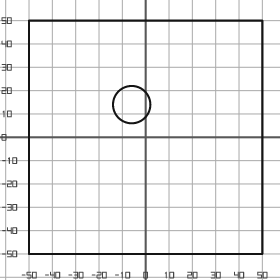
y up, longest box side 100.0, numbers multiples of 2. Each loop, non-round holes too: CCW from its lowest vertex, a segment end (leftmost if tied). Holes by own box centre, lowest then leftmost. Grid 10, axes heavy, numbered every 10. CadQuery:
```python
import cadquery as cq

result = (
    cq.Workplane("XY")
    .moveTo(-50.0, -50.0)
    .lineTo(50.0, -50.0)
    .lineTo(50.0, 50.0)
    .lineTo(-50.0, 50.0)
    .close()
    .moveTo(-6.0, 14.0)
    .circle(8.0)
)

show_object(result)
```